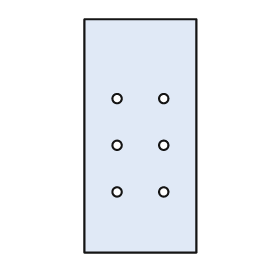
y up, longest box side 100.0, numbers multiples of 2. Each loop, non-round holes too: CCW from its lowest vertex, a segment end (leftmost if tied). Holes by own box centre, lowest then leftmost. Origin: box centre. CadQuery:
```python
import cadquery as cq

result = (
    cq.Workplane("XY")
    .moveTo(-24.0, -50.0)
    .lineTo(24.0, -50.0)
    .lineTo(24.0, 50.0)
    .lineTo(-24.0, 50.0)
    .close()
    .moveTo(-10.0, -24.0)
    .circle(2.0)
    .moveTo(10.0, -24.0)
    .circle(2.0)
    .moveTo(-10.0, -4.0)
    .circle(2.0)
    .moveTo(10.0, -4.0)
    .circle(2.0)
    .moveTo(-10.0, 16.0)
    .circle(2.0)
    .moveTo(10.0, 16.0)
    .circle(2.0)
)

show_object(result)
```